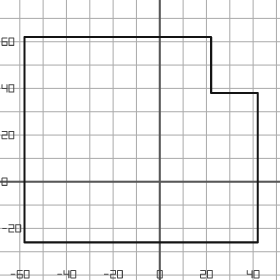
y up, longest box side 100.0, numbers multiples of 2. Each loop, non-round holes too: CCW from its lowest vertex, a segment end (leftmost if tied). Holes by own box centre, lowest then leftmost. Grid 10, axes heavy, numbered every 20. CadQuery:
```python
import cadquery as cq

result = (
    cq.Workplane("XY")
    .moveTo(-58.0, -26.0)
    .lineTo(42.0, -26.0)
    .lineTo(42.0, 38.0)
    .lineTo(22.0, 38.0)
    .lineTo(22.0, 62.0)
    .lineTo(-58.0, 62.0)
    .close()
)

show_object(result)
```